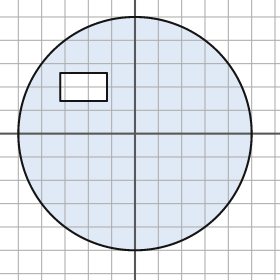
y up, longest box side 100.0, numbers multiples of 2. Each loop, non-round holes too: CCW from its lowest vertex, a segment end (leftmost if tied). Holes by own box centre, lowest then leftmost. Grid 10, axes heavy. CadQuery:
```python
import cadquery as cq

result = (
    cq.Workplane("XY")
    .moveTo(0.0, 0.0)
    .circle(50.0)
    .moveTo(-32.0, 14.0)
    .lineTo(-12.0, 14.0)
    .lineTo(-12.0, 26.0)
    .lineTo(-32.0, 26.0)
    .close()
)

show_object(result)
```